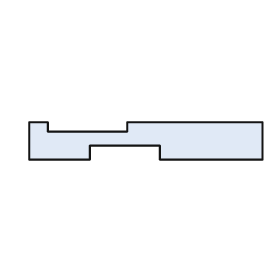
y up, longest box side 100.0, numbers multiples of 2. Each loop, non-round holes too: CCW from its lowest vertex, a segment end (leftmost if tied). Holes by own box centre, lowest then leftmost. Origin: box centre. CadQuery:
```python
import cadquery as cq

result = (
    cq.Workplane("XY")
    .moveTo(-50.0, -8.0)
    .lineTo(-24.0, -8.0)
    .lineTo(-24.0, -2.0)
    .lineTo(6.0, -2.0)
    .lineTo(6.0, -8.0)
    .lineTo(50.0, -8.0)
    .lineTo(50.0, 8.0)
    .lineTo(-8.0, 8.0)
    .lineTo(-8.0, 4.0)
    .lineTo(-42.0, 4.0)
    .lineTo(-42.0, 8.0)
    .lineTo(-50.0, 8.0)
    .close()
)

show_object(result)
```